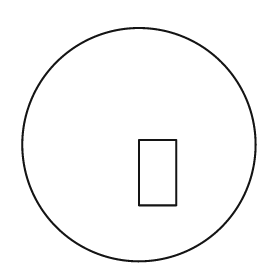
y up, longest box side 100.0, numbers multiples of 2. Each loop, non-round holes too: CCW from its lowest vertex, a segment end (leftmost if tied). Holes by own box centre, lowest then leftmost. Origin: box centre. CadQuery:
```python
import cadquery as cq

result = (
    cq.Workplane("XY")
    .moveTo(0.0, 0.0)
    .circle(50.0)
    .moveTo(0.0, -26.0)
    .lineTo(16.0, -26.0)
    .lineTo(16.0, 2.0)
    .lineTo(0.0, 2.0)
    .close()
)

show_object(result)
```